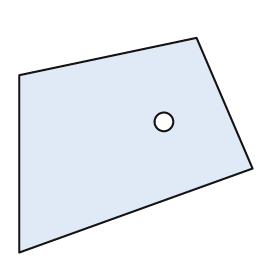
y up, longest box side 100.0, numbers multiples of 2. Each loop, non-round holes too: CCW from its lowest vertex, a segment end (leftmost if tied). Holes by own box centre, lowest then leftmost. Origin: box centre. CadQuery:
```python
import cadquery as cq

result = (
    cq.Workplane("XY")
    .moveTo(-50.0, -46.0)
    .lineTo(50.0, -10.0)
    .lineTo(26.0, 46.0)
    .lineTo(-50.0, 30.0)
    .close()
    .moveTo(12.0, 10.0)
    .circle(4.0)
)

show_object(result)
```